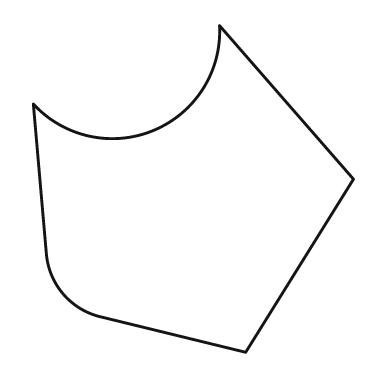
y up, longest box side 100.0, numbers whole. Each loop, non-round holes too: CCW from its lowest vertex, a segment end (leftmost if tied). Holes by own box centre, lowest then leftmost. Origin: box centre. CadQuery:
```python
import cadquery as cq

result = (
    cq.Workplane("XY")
    .moveTo(16.0, -50.0)
    .lineTo(49.0, 3.0)
    .lineTo(8.0, 50.0)
    .threePointArc((-12.0, 18.0), (-49.0, 26.0))
    .lineTo(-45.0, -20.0)
    .threePointArc((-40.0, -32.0), (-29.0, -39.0))
    .close()
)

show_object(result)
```